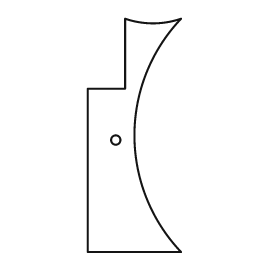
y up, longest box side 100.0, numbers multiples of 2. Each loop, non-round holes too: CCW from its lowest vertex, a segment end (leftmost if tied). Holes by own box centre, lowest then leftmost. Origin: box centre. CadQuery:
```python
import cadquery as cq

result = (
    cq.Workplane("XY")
    .moveTo(-20.0, -50.0)
    .lineTo(20.0, -50.0)
    .threePointArc((0.0, 0.0), (20.0, 50.0))
    .threePointArc((8.0, 48.0), (-4.0, 50.0))
    .lineTo(-4.0, 20.0)
    .lineTo(-20.0, 20.0)
    .close()
    .moveTo(-8.0, -2.0)
    .circle(2.0)
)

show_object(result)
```